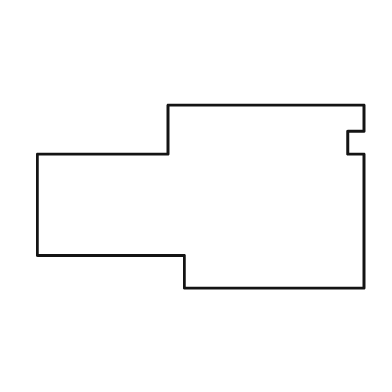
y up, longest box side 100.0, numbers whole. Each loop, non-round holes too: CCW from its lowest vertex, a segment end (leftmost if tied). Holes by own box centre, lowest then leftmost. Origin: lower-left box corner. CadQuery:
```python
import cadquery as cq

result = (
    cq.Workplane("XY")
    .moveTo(45.0, 0.0)
    .lineTo(100.0, 0.0)
    .lineTo(100.0, 41.0)
    .lineTo(95.0, 41.0)
    .lineTo(95.0, 48.0)
    .lineTo(100.0, 48.0)
    .lineTo(100.0, 56.0)
    .lineTo(40.0, 56.0)
    .lineTo(40.0, 41.0)
    .lineTo(0.0, 41.0)
    .lineTo(0.0, 10.0)
    .lineTo(45.0, 10.0)
    .close()
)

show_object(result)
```